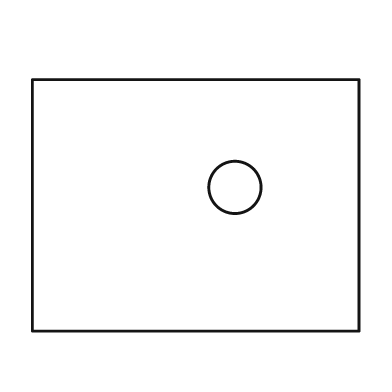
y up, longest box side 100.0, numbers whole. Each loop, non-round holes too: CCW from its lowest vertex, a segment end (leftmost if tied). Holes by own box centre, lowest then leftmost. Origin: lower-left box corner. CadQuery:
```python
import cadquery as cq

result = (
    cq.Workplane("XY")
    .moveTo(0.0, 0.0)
    .lineTo(100.0, 0.0)
    .lineTo(100.0, 77.0)
    .lineTo(0.0, 77.0)
    .close()
    .moveTo(62.0, 44.0)
    .circle(8.0)
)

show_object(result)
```